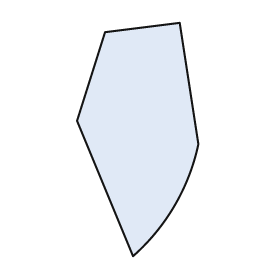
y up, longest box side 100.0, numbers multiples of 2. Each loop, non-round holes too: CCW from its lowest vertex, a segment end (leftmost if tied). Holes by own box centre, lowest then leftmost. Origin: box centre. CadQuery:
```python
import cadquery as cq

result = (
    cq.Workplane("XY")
    .moveTo(-2.0, -50.0)
    .threePointArc((16.0, -28.0), (26.0, -2.0))
    .lineTo(18.0, 50.0)
    .lineTo(-14.0, 46.0)
    .lineTo(-26.0, 8.0)
    .close()
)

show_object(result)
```